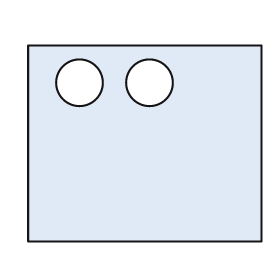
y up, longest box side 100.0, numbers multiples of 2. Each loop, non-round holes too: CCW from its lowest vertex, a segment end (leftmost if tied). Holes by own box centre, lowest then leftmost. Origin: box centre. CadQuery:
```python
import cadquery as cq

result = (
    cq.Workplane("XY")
    .moveTo(-50.0, -42.0)
    .lineTo(50.0, -42.0)
    .lineTo(50.0, 42.0)
    .lineTo(-50.0, 42.0)
    .close()
    .moveTo(-28.0, 26.0)
    .circle(10.0)
    .moveTo(2.0, 26.0)
    .circle(10.0)
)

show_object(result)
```